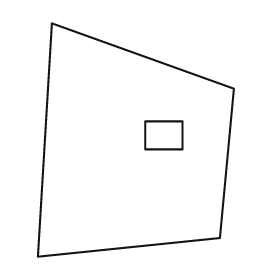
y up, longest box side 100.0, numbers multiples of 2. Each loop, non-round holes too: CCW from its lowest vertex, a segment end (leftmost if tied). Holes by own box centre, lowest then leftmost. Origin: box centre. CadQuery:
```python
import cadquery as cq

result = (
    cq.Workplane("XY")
    .moveTo(-42.0, -50.0)
    .lineTo(36.0, -42.0)
    .lineTo(42.0, 22.0)
    .lineTo(-36.0, 50.0)
    .close()
    .moveTo(4.0, -4.0)
    .lineTo(20.0, -4.0)
    .lineTo(20.0, 8.0)
    .lineTo(4.0, 8.0)
    .close()
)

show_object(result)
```